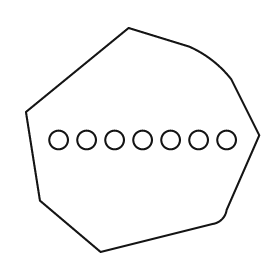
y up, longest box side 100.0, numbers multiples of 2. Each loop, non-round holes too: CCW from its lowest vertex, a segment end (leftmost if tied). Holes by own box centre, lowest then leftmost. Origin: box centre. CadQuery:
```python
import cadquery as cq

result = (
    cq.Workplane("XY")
    .moveTo(-18.0, -48.0)
    .lineTo(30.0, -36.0)
    .threePointArc((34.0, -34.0), (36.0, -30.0))
    .lineTo(50.0, 2.0)
    .lineTo(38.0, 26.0)
    .threePointArc((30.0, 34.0), (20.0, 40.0))
    .lineTo(-6.0, 48.0)
    .lineTo(-50.0, 12.0)
    .lineTo(-44.0, -26.0)
    .close()
    .moveTo(-36.0, 0.0)
    .circle(4.0)
    .moveTo(-24.0, 0.0)
    .circle(4.0)
    .moveTo(-12.0, 0.0)
    .circle(4.0)
    .moveTo(0.0, 0.0)
    .circle(4.0)
    .moveTo(12.0, 0.0)
    .circle(4.0)
    .moveTo(24.0, 0.0)
    .circle(4.0)
    .moveTo(36.0, 0.0)
    .circle(4.0)
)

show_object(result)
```